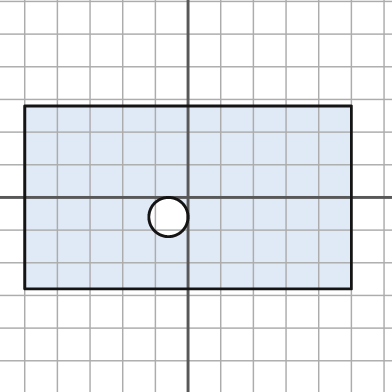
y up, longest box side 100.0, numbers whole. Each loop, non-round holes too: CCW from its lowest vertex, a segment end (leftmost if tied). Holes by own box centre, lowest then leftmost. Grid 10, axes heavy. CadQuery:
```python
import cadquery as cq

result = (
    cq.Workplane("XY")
    .moveTo(-50.0, -28.0)
    .lineTo(50.0, -28.0)
    .lineTo(50.0, 28.0)
    .lineTo(-50.0, 28.0)
    .close()
    .moveTo(-6.0, -6.0)
    .circle(6.0)
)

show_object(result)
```